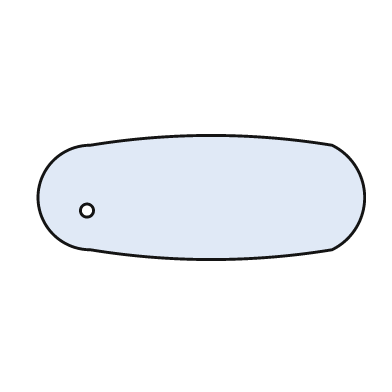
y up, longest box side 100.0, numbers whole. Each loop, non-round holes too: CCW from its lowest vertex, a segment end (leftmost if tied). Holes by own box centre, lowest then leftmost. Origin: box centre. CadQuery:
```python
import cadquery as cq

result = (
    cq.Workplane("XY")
    .moveTo(-34.0, -16.0)
    .threePointArc((3.0, -19.0), (40.0, -16.0))
    .threePointArc((50.0, 0.0), (40.0, 16.0))
    .threePointArc((3.0, 19.0), (-34.0, 16.0))
    .threePointArc((-50.0, 0.0), (-34.0, -16.0))
    .close()
    .moveTo(-35.0, -4.0)
    .circle(2.0)
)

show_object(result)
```